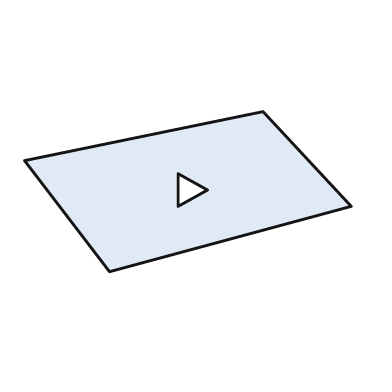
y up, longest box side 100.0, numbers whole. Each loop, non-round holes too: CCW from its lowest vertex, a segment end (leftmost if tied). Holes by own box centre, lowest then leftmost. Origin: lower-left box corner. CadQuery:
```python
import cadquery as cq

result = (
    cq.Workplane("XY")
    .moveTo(26.0, 0.0)
    .lineTo(100.0, 20.0)
    .lineTo(73.0, 49.0)
    .lineTo(0.0, 34.0)
    .close()
    .moveTo(47.0, 20.0)
    .lineTo(56.0, 25.0)
    .lineTo(47.0, 30.0)
    .close()
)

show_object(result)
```